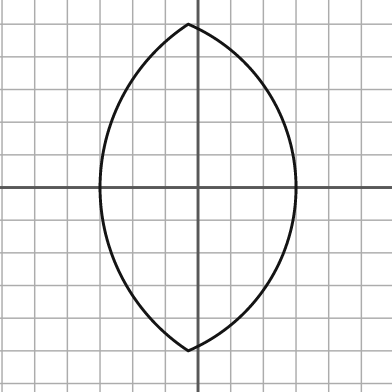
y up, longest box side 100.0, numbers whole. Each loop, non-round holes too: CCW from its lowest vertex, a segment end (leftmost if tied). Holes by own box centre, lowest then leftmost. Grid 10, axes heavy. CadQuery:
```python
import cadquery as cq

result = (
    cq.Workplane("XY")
    .moveTo(-3.0, -50.0)
    .threePointArc((30.0, 0.0), (-3.0, 50.0))
    .threePointArc((-30.0, 0.0), (-3.0, -50.0))
    .close()
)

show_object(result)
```